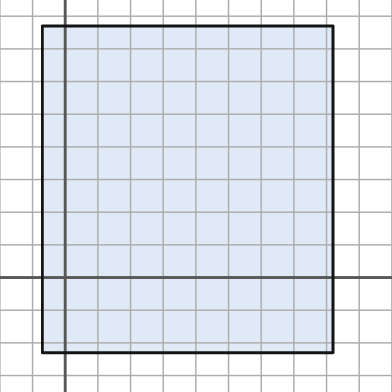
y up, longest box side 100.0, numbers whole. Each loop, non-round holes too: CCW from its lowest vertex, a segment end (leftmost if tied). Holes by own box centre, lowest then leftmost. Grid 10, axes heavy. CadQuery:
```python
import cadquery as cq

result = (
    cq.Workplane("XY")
    .moveTo(-7.0, -23.0)
    .lineTo(82.0, -23.0)
    .lineTo(82.0, 77.0)
    .lineTo(-7.0, 77.0)
    .close()
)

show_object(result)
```